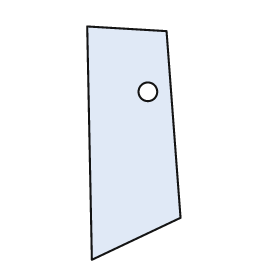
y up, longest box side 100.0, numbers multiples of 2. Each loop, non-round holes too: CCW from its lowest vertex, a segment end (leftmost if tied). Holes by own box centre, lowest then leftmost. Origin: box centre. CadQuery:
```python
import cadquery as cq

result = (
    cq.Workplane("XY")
    .moveTo(-18.0, -50.0)
    .lineTo(20.0, -32.0)
    .lineTo(14.0, 48.0)
    .lineTo(-20.0, 50.0)
    .close()
    .moveTo(6.0, 22.0)
    .circle(4.0)
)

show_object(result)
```